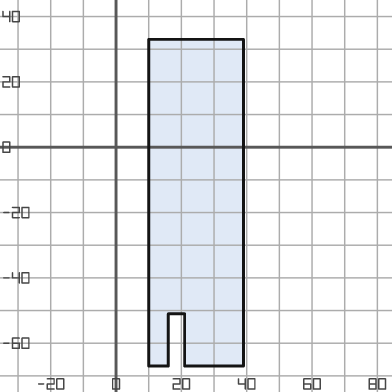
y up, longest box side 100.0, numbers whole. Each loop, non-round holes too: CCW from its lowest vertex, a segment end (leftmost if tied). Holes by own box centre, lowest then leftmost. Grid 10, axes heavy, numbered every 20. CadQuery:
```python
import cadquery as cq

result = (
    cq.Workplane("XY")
    .moveTo(10.0, -67.0)
    .lineTo(16.0, -67.0)
    .lineTo(16.0, -51.0)
    .lineTo(21.0, -51.0)
    .lineTo(21.0, -67.0)
    .lineTo(39.0, -67.0)
    .lineTo(39.0, 33.0)
    .lineTo(10.0, 33.0)
    .close()
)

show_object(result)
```